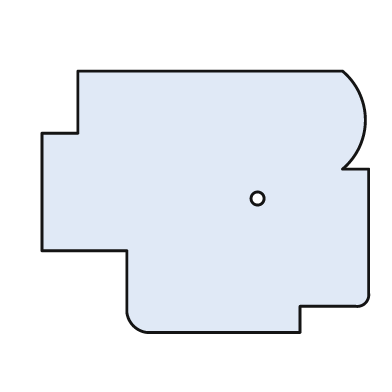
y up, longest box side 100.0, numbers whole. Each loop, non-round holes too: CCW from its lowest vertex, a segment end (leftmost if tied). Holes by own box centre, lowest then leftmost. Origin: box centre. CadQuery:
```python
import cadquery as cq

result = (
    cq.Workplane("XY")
    .moveTo(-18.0, -40.0)
    .lineTo(29.0, -40.0)
    .lineTo(29.0, -32.0)
    .lineTo(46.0, -32.0)
    .threePointArc((49.0, -31.0), (50.0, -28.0))
    .lineTo(50.0, 10.0)
    .lineTo(42.0, 10.0)
    .threePointArc((49.0, 25.0), (42.0, 40.0))
    .lineTo(-39.0, 40.0)
    .lineTo(-39.0, 21.0)
    .lineTo(-50.0, 21.0)
    .lineTo(-50.0, -15.0)
    .lineTo(-24.0, -15.0)
    .lineTo(-24.0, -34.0)
    .threePointArc((-22.0, -38.0), (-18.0, -40.0))
    .close()
    .moveTo(16.0, 1.0)
    .circle(2.0)
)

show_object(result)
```